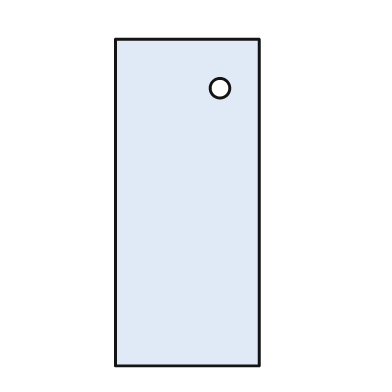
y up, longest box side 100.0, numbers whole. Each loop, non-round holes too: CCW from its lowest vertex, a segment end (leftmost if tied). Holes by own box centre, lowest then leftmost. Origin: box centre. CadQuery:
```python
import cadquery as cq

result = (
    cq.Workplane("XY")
    .moveTo(-22.0, -50.0)
    .lineTo(22.0, -50.0)
    .lineTo(22.0, 50.0)
    .lineTo(-22.0, 50.0)
    .close()
    .moveTo(10.0, 35.0)
    .circle(3.0)
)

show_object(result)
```